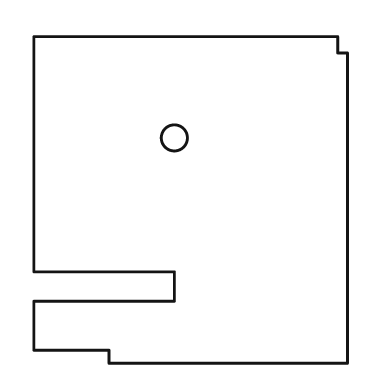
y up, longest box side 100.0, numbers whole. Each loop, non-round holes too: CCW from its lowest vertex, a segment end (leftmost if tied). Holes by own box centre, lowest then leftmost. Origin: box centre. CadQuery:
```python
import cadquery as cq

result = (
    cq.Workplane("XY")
    .moveTo(-25.0, -50.0)
    .lineTo(48.0, -50.0)
    .lineTo(48.0, 45.0)
    .lineTo(45.0, 45.0)
    .lineTo(45.0, 50.0)
    .lineTo(-48.0, 50.0)
    .lineTo(-48.0, -22.0)
    .lineTo(-5.0, -22.0)
    .lineTo(-5.0, -31.0)
    .lineTo(-48.0, -31.0)
    .lineTo(-48.0, -46.0)
    .lineTo(-25.0, -46.0)
    .close()
    .moveTo(-5.0, 19.0)
    .circle(4.0)
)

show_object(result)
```